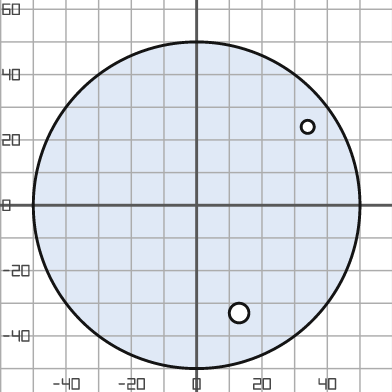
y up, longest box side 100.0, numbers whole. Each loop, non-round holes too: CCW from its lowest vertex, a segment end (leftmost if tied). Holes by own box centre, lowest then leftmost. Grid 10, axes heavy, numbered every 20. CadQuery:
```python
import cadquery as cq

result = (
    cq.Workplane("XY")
    .moveTo(0.0, 0.0)
    .circle(50.0)
    .moveTo(13.0, -33.0)
    .circle(3.0)
    .moveTo(34.0, 24.0)
    .circle(2.0)
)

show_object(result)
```